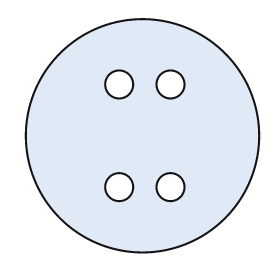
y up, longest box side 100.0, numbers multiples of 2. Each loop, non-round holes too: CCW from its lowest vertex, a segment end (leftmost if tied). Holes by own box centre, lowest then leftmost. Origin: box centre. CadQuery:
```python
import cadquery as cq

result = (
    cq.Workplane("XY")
    .moveTo(0.0, 0.0)
    .circle(50.0)
    .moveTo(-10.0, -22.0)
    .circle(6.0)
    .moveTo(12.0, -22.0)
    .circle(6.0)
    .moveTo(-10.0, 22.0)
    .circle(6.0)
    .moveTo(12.0, 22.0)
    .circle(6.0)
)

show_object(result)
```